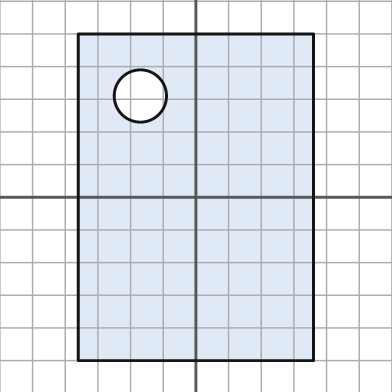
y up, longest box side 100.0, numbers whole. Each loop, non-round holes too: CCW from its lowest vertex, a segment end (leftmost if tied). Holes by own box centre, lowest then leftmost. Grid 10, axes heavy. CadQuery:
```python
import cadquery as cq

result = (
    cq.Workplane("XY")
    .moveTo(-36.0, -50.0)
    .lineTo(36.0, -50.0)
    .lineTo(36.0, 50.0)
    .lineTo(-36.0, 50.0)
    .close()
    .moveTo(-17.0, 31.0)
    .circle(8.0)
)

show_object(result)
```